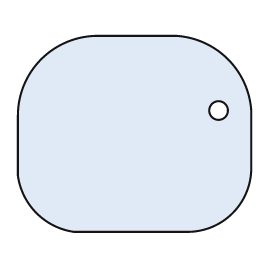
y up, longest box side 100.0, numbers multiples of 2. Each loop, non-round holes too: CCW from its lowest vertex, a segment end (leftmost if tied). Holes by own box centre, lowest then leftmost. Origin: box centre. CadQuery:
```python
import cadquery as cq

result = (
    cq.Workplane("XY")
    .moveTo(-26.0, -42.0)
    .lineTo(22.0, -42.0)
    .threePointArc((42.0, -34.0), (50.0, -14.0))
    .lineTo(50.0, 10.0)
    .threePointArc((40.0, 32.0), (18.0, 42.0))
    .lineTo(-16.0, 42.0)
    .threePointArc((-40.0, 32.0), (-50.0, 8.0))
    .lineTo(-50.0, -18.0)
    .threePointArc((-42.0, -34.0), (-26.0, -42.0))
    .close()
    .moveTo(36.0, 10.0)
    .circle(4.0)
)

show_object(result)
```